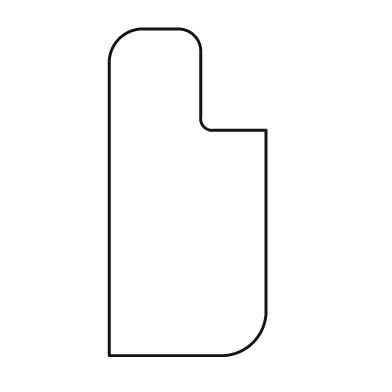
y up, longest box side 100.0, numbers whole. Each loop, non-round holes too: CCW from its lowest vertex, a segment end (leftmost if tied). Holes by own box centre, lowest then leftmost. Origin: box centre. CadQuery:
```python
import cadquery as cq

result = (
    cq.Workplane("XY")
    .moveTo(-24.0, -50.0)
    .lineTo(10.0, -50.0)
    .threePointArc((20.0, -46.0), (24.0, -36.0))
    .lineTo(24.0, 19.0)
    .lineTo(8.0, 19.0)
    .threePointArc((5.0, 20.0), (4.0, 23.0))
    .lineTo(4.0, 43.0)
    .threePointArc((2.0, 48.0), (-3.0, 50.0))
    .lineTo(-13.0, 50.0)
    .threePointArc((-21.0, 47.0), (-24.0, 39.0))
    .close()
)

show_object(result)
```